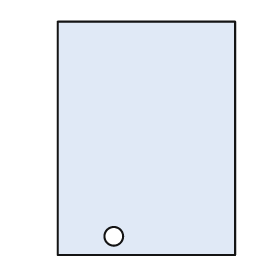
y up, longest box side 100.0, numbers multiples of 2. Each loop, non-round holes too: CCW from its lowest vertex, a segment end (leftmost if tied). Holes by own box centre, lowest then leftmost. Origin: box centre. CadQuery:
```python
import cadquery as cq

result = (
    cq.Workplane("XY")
    .moveTo(-38.0, -50.0)
    .lineTo(38.0, -50.0)
    .lineTo(38.0, 50.0)
    .lineTo(-38.0, 50.0)
    .close()
    .moveTo(-14.0, -42.0)
    .circle(4.0)
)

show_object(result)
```